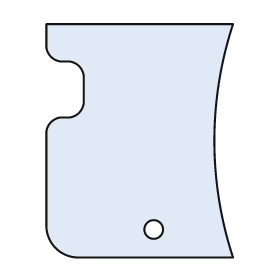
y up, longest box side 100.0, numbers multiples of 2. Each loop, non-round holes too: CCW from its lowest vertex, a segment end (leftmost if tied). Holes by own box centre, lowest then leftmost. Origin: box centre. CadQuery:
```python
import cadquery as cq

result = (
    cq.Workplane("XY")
    .moveTo(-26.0, -50.0)
    .lineTo(40.0, -50.0)
    .threePointArc((32.0, 0.0), (40.0, 50.0))
    .lineTo(-40.0, 50.0)
    .lineTo(-40.0, 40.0)
    .threePointArc((-38.0, 36.0), (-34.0, 34.0))
    .lineTo(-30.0, 34.0)
    .threePointArc((-26.0, 32.0), (-24.0, 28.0))
    .lineTo(-24.0, 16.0)
    .threePointArc((-26.0, 12.0), (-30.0, 10.0))
    .lineTo(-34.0, 10.0)
    .threePointArc((-38.0, 8.0), (-40.0, 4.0))
    .lineTo(-40.0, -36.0)
    .threePointArc((-36.0, -46.0), (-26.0, -50.0))
    .close()
    .moveTo(6.0, -38.0)
    .circle(4.0)
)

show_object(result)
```